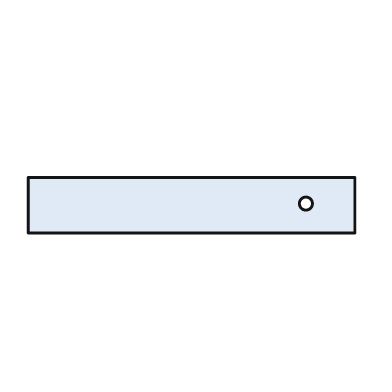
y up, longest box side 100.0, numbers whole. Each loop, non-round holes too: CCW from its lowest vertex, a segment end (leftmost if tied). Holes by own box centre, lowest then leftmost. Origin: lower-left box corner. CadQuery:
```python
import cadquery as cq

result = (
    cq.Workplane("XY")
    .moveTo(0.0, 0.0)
    .lineTo(100.0, 0.0)
    .lineTo(100.0, 17.0)
    .lineTo(0.0, 17.0)
    .close()
    .moveTo(85.0, 9.0)
    .circle(2.0)
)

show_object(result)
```